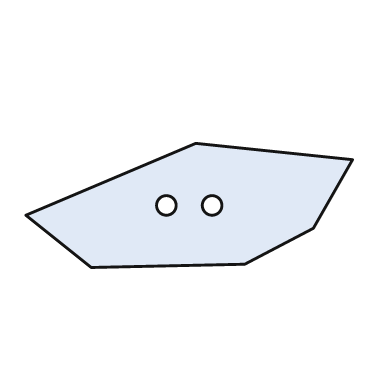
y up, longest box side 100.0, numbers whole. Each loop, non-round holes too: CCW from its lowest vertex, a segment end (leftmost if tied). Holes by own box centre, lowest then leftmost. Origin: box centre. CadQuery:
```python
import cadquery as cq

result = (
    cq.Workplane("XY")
    .moveTo(-30.0, -19.0)
    .lineTo(17.0, -18.0)
    .lineTo(38.0, -7.0)
    .lineTo(50.0, 14.0)
    .lineTo(2.0, 19.0)
    .lineTo(-50.0, -3.0)
    .close()
    .moveTo(-7.0, 0.0)
    .circle(3.0)
    .moveTo(7.0, 0.0)
    .circle(3.0)
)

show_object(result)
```